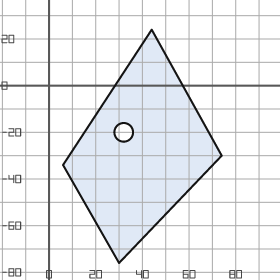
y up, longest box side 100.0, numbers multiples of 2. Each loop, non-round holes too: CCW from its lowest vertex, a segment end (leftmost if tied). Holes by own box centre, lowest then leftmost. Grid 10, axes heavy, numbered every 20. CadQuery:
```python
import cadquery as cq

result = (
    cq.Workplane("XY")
    .moveTo(30.0, -76.0)
    .lineTo(74.0, -30.0)
    .lineTo(44.0, 24.0)
    .lineTo(6.0, -34.0)
    .close()
    .moveTo(32.0, -20.0)
    .circle(4.0)
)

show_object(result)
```